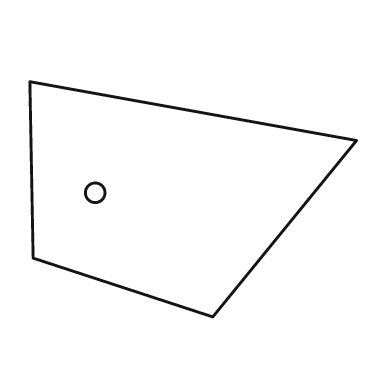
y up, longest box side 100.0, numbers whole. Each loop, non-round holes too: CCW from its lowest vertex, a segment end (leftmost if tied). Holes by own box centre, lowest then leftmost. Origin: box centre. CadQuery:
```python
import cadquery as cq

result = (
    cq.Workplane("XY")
    .moveTo(6.0, -36.0)
    .lineTo(50.0, 18.0)
    .lineTo(-50.0, 36.0)
    .lineTo(-49.0, -18.0)
    .close()
    .moveTo(-30.0, 2.0)
    .circle(3.0)
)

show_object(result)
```